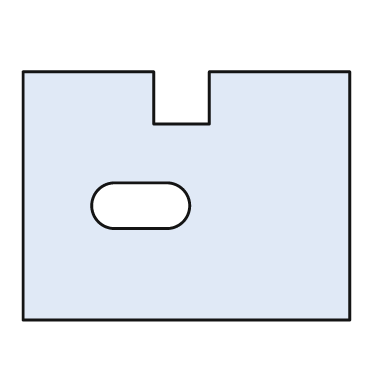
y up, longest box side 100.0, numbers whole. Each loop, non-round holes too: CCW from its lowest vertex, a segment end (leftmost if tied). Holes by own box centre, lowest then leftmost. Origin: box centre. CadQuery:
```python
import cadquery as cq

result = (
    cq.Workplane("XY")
    .moveTo(-50.0, -38.0)
    .lineTo(50.0, -38.0)
    .lineTo(50.0, 38.0)
    .lineTo(7.0, 38.0)
    .lineTo(7.0, 22.0)
    .lineTo(-10.0, 22.0)
    .lineTo(-10.0, 38.0)
    .lineTo(-50.0, 38.0)
    .close()
    .moveTo(-22.0, -10.0)
    .lineTo(-6.0, -10.0)
    .threePointArc((1.0, -3.0), (-6.0, 4.0))
    .lineTo(-22.0, 4.0)
    .threePointArc((-29.0, -3.0), (-22.0, -10.0))
    .close()
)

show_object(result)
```